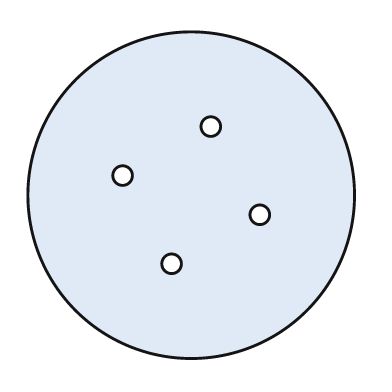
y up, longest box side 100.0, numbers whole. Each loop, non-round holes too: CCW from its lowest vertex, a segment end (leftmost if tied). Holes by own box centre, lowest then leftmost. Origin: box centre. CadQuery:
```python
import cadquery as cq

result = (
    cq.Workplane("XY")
    .moveTo(0.0, 0.0)
    .circle(50.0)
    .moveTo(-6.0, -21.0)
    .circle(3.0)
    .moveTo(21.0, -6.0)
    .circle(3.0)
    .moveTo(-21.0, 6.0)
    .circle(3.0)
    .moveTo(6.0, 21.0)
    .circle(3.0)
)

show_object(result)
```